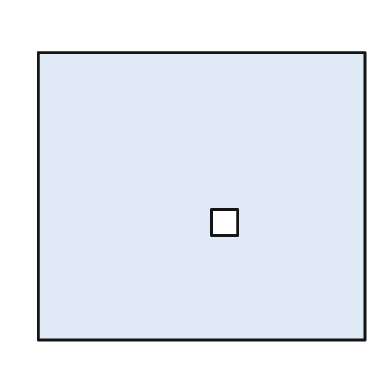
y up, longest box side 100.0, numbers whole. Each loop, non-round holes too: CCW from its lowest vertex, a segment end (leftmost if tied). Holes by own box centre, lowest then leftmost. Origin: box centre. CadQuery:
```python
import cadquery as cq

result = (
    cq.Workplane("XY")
    .moveTo(-50.0, -44.0)
    .lineTo(50.0, -44.0)
    .lineTo(50.0, 44.0)
    .lineTo(-50.0, 44.0)
    .close()
    .moveTo(3.0, -12.0)
    .lineTo(11.0, -12.0)
    .lineTo(11.0, -4.0)
    .lineTo(3.0, -4.0)
    .close()
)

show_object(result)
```